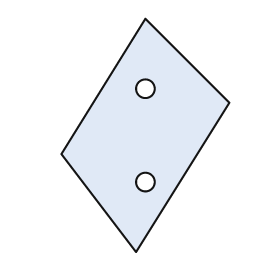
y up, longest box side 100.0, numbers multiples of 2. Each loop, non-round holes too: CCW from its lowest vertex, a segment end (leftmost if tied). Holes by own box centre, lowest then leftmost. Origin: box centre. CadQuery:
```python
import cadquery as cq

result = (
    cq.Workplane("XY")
    .moveTo(-4.0, -50.0)
    .lineTo(36.0, 14.0)
    .lineTo(0.0, 50.0)
    .lineTo(-36.0, -8.0)
    .close()
    .moveTo(0.0, -20.0)
    .circle(4.0)
    .moveTo(0.0, 20.0)
    .circle(4.0)
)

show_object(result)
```